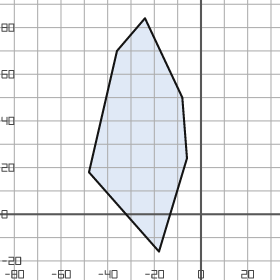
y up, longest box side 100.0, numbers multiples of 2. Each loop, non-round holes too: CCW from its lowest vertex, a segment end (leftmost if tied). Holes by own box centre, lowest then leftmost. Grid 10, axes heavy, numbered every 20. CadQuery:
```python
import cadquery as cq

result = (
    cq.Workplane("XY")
    .moveTo(-18.0, -16.0)
    .lineTo(-6.0, 24.0)
    .lineTo(-8.0, 50.0)
    .lineTo(-24.0, 84.0)
    .lineTo(-36.0, 70.0)
    .lineTo(-48.0, 18.0)
    .close()
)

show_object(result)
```